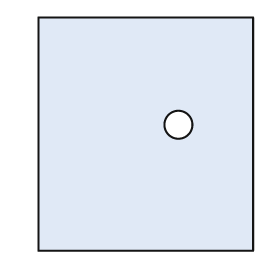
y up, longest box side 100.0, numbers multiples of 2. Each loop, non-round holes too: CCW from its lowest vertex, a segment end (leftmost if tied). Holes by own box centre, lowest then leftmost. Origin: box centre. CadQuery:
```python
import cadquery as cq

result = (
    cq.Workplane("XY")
    .moveTo(-46.0, -50.0)
    .lineTo(46.0, -50.0)
    .lineTo(46.0, 50.0)
    .lineTo(-46.0, 50.0)
    .close()
    .moveTo(14.0, 4.0)
    .circle(6.0)
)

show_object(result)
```